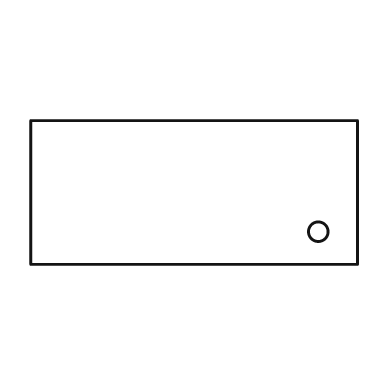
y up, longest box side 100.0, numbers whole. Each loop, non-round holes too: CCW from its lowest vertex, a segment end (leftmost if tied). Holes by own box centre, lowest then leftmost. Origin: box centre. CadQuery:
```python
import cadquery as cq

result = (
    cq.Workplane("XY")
    .moveTo(-50.0, -22.0)
    .lineTo(50.0, -22.0)
    .lineTo(50.0, 22.0)
    .lineTo(-50.0, 22.0)
    .close()
    .moveTo(38.0, -12.0)
    .circle(3.0)
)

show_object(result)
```